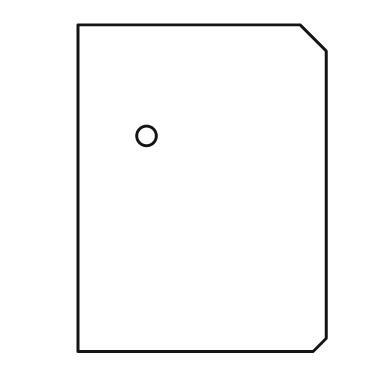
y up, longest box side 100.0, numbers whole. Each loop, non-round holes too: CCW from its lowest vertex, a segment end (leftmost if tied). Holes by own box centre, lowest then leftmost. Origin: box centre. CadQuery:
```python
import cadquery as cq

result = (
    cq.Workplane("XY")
    .moveTo(-38.0, -50.0)
    .lineTo(34.0, -50.0)
    .lineTo(38.0, -46.0)
    .lineTo(38.0, 42.0)
    .lineTo(30.0, 50.0)
    .lineTo(-38.0, 50.0)
    .close()
    .moveTo(-17.0, 16.0)
    .circle(3.0)
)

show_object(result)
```